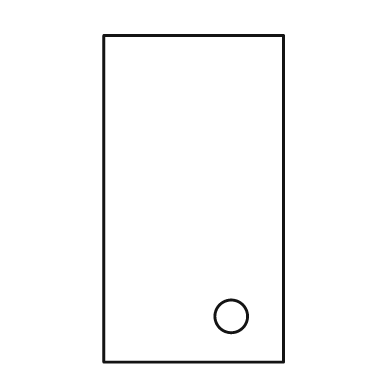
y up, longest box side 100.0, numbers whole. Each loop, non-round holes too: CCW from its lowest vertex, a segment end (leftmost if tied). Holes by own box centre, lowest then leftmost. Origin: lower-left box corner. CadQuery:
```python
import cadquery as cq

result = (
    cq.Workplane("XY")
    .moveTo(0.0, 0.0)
    .lineTo(55.0, 0.0)
    .lineTo(55.0, 100.0)
    .lineTo(0.0, 100.0)
    .close()
    .moveTo(39.0, 14.0)
    .circle(5.0)
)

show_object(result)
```